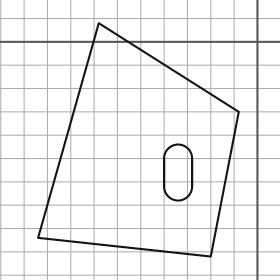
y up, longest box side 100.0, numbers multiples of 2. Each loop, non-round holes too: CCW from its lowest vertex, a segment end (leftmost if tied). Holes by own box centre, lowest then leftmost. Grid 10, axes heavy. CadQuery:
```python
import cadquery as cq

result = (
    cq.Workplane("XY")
    .moveTo(-20.0, -92.0)
    .lineTo(-8.0, -30.0)
    .lineTo(-68.0, 8.0)
    .lineTo(-94.0, -84.0)
    .close()
    .moveTo(-40.0, -62.0)
    .threePointArc((-34.0, -68.0), (-28.0, -62.0))
    .lineTo(-28.0, -50.0)
    .threePointArc((-34.0, -44.0), (-40.0, -50.0))
    .close()
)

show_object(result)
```